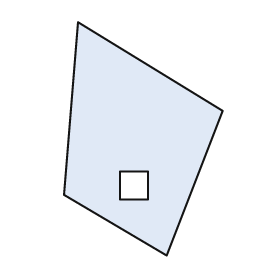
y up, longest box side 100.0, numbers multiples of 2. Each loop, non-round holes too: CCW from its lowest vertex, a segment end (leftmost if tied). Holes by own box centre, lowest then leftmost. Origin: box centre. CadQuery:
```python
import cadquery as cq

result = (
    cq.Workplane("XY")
    .moveTo(10.0, -50.0)
    .lineTo(34.0, 12.0)
    .lineTo(-28.0, 50.0)
    .lineTo(-34.0, -24.0)
    .close()
    .moveTo(-10.0, -26.0)
    .lineTo(2.0, -26.0)
    .lineTo(2.0, -14.0)
    .lineTo(-10.0, -14.0)
    .close()
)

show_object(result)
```